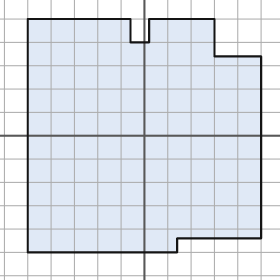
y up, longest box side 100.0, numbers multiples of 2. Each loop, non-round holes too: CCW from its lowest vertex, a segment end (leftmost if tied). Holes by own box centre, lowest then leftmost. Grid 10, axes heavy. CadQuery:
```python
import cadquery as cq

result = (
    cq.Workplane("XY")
    .moveTo(-50.0, -50.0)
    .lineTo(14.0, -50.0)
    .lineTo(14.0, -44.0)
    .lineTo(50.0, -44.0)
    .lineTo(50.0, 34.0)
    .lineTo(30.0, 34.0)
    .lineTo(30.0, 50.0)
    .lineTo(2.0, 50.0)
    .lineTo(2.0, 40.0)
    .lineTo(-6.0, 40.0)
    .lineTo(-6.0, 50.0)
    .lineTo(-50.0, 50.0)
    .close()
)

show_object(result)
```